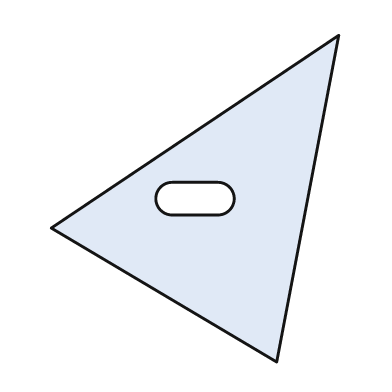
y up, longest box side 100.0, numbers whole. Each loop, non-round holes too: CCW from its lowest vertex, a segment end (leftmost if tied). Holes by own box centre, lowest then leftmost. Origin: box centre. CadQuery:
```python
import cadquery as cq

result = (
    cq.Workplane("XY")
    .moveTo(25.0, -50.0)
    .lineTo(44.0, 50.0)
    .lineTo(-44.0, -9.0)
    .close()
    .moveTo(-7.0, -5.0)
    .lineTo(7.0, -5.0)
    .threePointArc((12.0, 0.0), (7.0, 5.0))
    .lineTo(-7.0, 5.0)
    .threePointArc((-12.0, 0.0), (-7.0, -5.0))
    .close()
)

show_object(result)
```